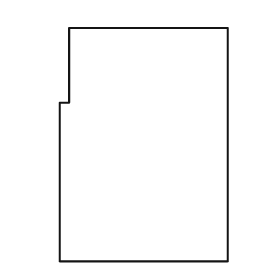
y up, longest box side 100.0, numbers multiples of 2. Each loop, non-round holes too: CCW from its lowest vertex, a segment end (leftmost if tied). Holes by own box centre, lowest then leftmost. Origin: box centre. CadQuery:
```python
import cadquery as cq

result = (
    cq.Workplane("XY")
    .moveTo(-36.0, -50.0)
    .lineTo(36.0, -50.0)
    .lineTo(36.0, 50.0)
    .lineTo(-32.0, 50.0)
    .lineTo(-32.0, 18.0)
    .lineTo(-36.0, 18.0)
    .close()
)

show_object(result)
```